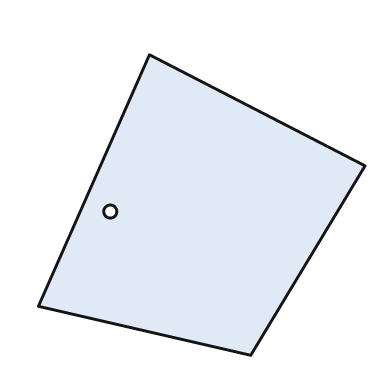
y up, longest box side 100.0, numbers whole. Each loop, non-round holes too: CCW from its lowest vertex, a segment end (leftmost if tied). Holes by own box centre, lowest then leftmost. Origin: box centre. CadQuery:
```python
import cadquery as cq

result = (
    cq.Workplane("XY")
    .moveTo(15.0, -46.0)
    .lineTo(50.0, 12.0)
    .lineTo(-16.0, 46.0)
    .lineTo(-50.0, -31.0)
    .close()
    .moveTo(-28.0, -2.0)
    .circle(2.0)
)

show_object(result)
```